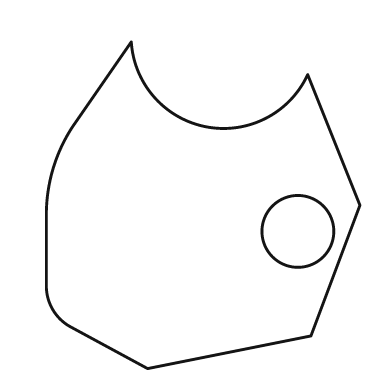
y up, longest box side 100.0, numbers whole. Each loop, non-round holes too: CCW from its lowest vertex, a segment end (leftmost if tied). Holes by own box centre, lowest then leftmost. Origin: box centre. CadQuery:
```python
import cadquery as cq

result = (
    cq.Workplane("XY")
    .moveTo(-17.0, -50.0)
    .lineTo(33.0, -40.0)
    .lineTo(48.0, 0.0)
    .lineTo(32.0, 40.0)
    .threePointArc((1.0, 24.0), (-22.0, 50.0))
    .lineTo(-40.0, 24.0)
    .threePointArc((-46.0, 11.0), (-48.0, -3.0))
    .lineTo(-48.0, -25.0)
    .threePointArc((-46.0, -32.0), (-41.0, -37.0))
    .close()
    .moveTo(29.0, -8.0)
    .circle(11.0)
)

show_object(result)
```